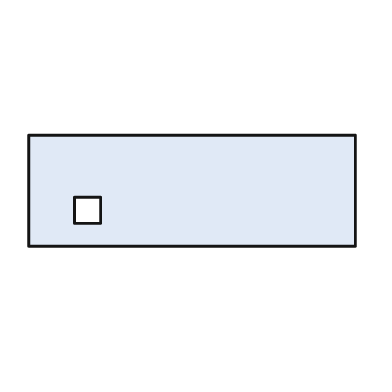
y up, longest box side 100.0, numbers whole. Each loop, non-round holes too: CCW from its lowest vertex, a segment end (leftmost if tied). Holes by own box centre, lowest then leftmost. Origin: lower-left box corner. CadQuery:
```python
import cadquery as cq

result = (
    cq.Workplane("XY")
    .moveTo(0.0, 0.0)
    .lineTo(100.0, 0.0)
    .lineTo(100.0, 34.0)
    .lineTo(0.0, 34.0)
    .close()
    .moveTo(14.0, 7.0)
    .lineTo(22.0, 7.0)
    .lineTo(22.0, 15.0)
    .lineTo(14.0, 15.0)
    .close()
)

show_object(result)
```